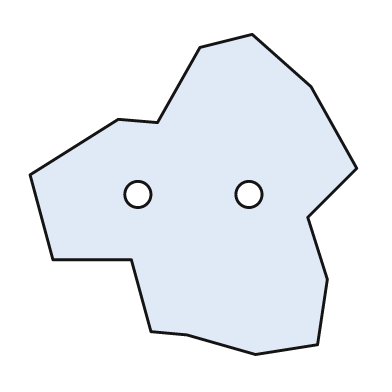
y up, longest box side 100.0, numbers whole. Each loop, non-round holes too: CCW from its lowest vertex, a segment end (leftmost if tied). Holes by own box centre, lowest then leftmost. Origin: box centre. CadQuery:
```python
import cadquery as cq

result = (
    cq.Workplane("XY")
    .moveTo(19.0, -49.0)
    .lineTo(38.0, -46.0)
    .lineTo(41.0, -26.0)
    .lineTo(35.0, -7.0)
    .lineTo(50.0, 8.0)
    .lineTo(36.0, 33.0)
    .lineTo(18.0, 49.0)
    .lineTo(2.0, 45.0)
    .lineTo(-11.0, 22.0)
    .lineTo(-23.0, 23.0)
    .lineTo(-50.0, 6.0)
    .lineTo(-43.0, -20.0)
    .lineTo(-19.0, -20.0)
    .lineTo(-13.0, -42.0)
    .lineTo(-2.0, -43.0)
    .close()
    .moveTo(-17.0, 0.0)
    .circle(4.0)
    .moveTo(17.0, 0.0)
    .circle(4.0)
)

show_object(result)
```